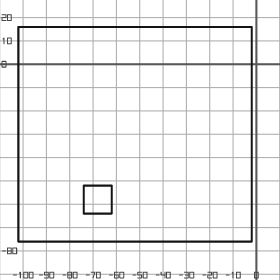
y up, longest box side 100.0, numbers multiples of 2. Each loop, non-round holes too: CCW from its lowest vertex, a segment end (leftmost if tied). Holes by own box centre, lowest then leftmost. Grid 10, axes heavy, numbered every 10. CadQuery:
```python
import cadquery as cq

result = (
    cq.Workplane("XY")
    .moveTo(-102.0, -76.0)
    .lineTo(-2.0, -76.0)
    .lineTo(-2.0, 16.0)
    .lineTo(-102.0, 16.0)
    .close()
    .moveTo(-74.0, -64.0)
    .lineTo(-62.0, -64.0)
    .lineTo(-62.0, -52.0)
    .lineTo(-74.0, -52.0)
    .close()
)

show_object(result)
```